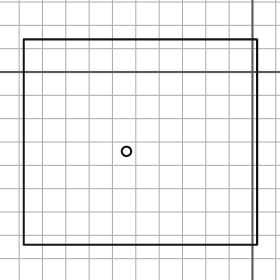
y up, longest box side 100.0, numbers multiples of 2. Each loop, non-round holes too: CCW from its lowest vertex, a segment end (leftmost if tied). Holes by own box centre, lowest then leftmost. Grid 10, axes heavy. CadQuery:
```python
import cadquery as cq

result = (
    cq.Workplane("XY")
    .moveTo(-98.0, -74.0)
    .lineTo(2.0, -74.0)
    .lineTo(2.0, 14.0)
    .lineTo(-98.0, 14.0)
    .close()
    .moveTo(-54.0, -34.0)
    .circle(2.0)
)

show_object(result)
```